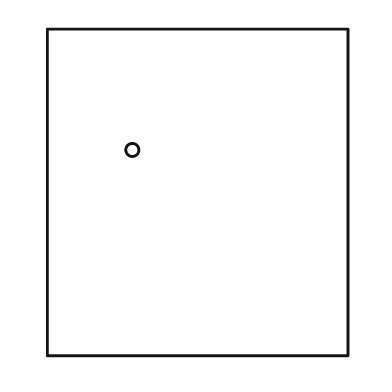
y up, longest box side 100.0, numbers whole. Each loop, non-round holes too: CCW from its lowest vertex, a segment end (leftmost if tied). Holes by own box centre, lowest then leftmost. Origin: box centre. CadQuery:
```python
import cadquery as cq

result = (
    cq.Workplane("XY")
    .moveTo(-46.0, -50.0)
    .lineTo(46.0, -50.0)
    .lineTo(46.0, 50.0)
    .lineTo(-46.0, 50.0)
    .close()
    .moveTo(-20.0, 13.0)
    .circle(2.0)
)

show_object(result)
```